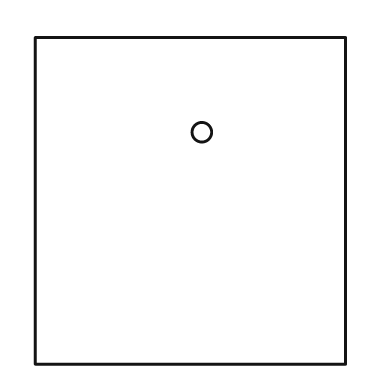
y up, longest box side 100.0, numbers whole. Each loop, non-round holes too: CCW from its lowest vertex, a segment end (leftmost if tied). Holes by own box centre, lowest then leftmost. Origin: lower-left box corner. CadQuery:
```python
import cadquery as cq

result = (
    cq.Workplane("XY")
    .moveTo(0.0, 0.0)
    .lineTo(95.0, 0.0)
    .lineTo(95.0, 100.0)
    .lineTo(0.0, 100.0)
    .close()
    .moveTo(51.0, 71.0)
    .circle(3.0)
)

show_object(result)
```